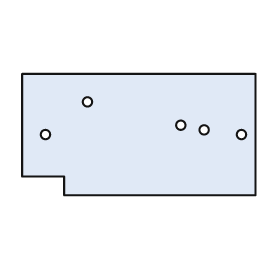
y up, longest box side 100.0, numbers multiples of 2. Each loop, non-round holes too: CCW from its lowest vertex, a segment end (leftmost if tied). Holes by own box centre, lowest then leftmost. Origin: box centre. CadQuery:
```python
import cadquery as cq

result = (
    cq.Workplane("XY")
    .moveTo(-32.0, -26.0)
    .lineTo(50.0, -26.0)
    .lineTo(50.0, 26.0)
    .lineTo(-50.0, 26.0)
    .lineTo(-50.0, -18.0)
    .lineTo(-32.0, -18.0)
    .close()
    .moveTo(-40.0, 0.0)
    .circle(2.0)
    .moveTo(44.0, 0.0)
    .circle(2.0)
    .moveTo(28.0, 2.0)
    .circle(2.0)
    .moveTo(18.0, 4.0)
    .circle(2.0)
    .moveTo(-22.0, 14.0)
    .circle(2.0)
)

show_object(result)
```